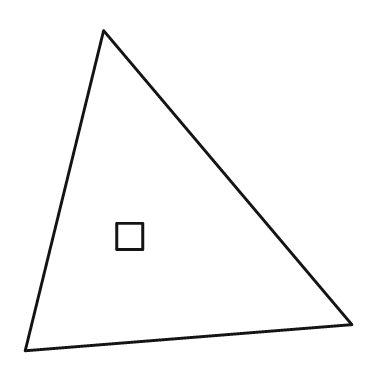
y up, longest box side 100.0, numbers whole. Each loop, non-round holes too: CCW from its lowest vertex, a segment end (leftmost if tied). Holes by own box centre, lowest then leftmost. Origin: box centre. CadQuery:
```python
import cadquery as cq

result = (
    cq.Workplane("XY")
    .moveTo(-50.0, -49.0)
    .lineTo(50.0, -41.0)
    .lineTo(-26.0, 49.0)
    .close()
    .moveTo(-22.0, -18.0)
    .lineTo(-14.0, -18.0)
    .lineTo(-14.0, -10.0)
    .lineTo(-22.0, -10.0)
    .close()
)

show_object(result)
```